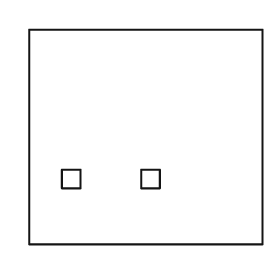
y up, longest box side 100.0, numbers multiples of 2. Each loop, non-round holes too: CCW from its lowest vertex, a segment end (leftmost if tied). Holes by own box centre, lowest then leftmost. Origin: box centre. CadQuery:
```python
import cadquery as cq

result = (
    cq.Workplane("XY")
    .moveTo(-50.0, -46.0)
    .lineTo(50.0, -46.0)
    .lineTo(50.0, 46.0)
    .lineTo(-50.0, 46.0)
    .close()
    .moveTo(-36.0, -22.0)
    .lineTo(-28.0, -22.0)
    .lineTo(-28.0, -14.0)
    .lineTo(-36.0, -14.0)
    .close()
    .moveTo(-2.0, -22.0)
    .lineTo(6.0, -22.0)
    .lineTo(6.0, -14.0)
    .lineTo(-2.0, -14.0)
    .close()
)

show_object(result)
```